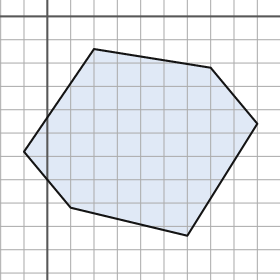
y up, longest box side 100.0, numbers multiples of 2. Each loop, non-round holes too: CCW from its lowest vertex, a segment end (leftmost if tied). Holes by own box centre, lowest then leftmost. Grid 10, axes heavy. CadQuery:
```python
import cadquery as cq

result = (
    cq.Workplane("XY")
    .moveTo(60.0, -94.0)
    .lineTo(90.0, -46.0)
    .lineTo(70.0, -22.0)
    .lineTo(20.0, -14.0)
    .lineTo(-10.0, -58.0)
    .lineTo(10.0, -82.0)
    .close()
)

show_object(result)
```